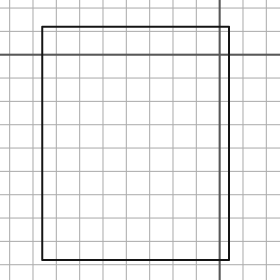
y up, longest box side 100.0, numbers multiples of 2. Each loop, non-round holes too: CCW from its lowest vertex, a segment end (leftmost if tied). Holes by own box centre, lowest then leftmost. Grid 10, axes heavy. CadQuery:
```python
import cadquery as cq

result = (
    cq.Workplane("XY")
    .moveTo(-76.0, -88.0)
    .lineTo(4.0, -88.0)
    .lineTo(4.0, 12.0)
    .lineTo(-76.0, 12.0)
    .close()
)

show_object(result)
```